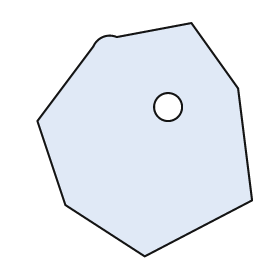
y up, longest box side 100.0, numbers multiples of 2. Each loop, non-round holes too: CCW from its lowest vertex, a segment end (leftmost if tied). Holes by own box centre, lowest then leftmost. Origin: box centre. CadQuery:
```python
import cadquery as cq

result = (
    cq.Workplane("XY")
    .moveTo(0.0, -50.0)
    .lineTo(46.0, -26.0)
    .lineTo(40.0, 22.0)
    .lineTo(20.0, 50.0)
    .lineTo(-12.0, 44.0)
    .threePointArc((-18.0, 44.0), (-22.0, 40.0))
    .lineTo(-46.0, 8.0)
    .lineTo(-34.0, -28.0)
    .close()
    .moveTo(10.0, 14.0)
    .circle(6.0)
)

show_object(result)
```